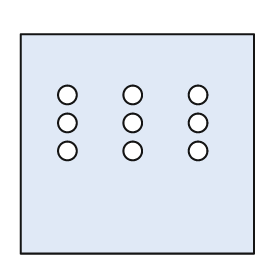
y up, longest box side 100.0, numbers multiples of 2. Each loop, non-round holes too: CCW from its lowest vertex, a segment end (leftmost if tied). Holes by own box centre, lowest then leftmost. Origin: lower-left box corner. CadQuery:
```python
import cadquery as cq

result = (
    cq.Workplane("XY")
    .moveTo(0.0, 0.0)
    .lineTo(100.0, 0.0)
    .lineTo(100.0, 94.0)
    .lineTo(0.0, 94.0)
    .close()
    .moveTo(20.0, 44.0)
    .circle(4.0)
    .moveTo(48.0, 44.0)
    .circle(4.0)
    .moveTo(76.0, 44.0)
    .circle(4.0)
    .moveTo(20.0, 56.0)
    .circle(4.0)
    .moveTo(48.0, 56.0)
    .circle(4.0)
    .moveTo(76.0, 56.0)
    .circle(4.0)
    .moveTo(20.0, 68.0)
    .circle(4.0)
    .moveTo(48.0, 68.0)
    .circle(4.0)
    .moveTo(76.0, 68.0)
    .circle(4.0)
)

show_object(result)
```